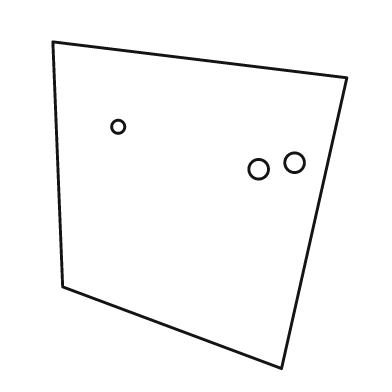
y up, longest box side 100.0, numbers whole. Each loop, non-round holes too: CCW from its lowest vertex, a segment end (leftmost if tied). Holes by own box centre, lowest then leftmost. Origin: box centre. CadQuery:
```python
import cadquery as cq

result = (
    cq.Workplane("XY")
    .moveTo(25.0, -50.0)
    .lineTo(45.0, 39.0)
    .lineTo(-45.0, 50.0)
    .lineTo(-42.0, -25.0)
    .close()
    .moveTo(18.0, 11.0)
    .circle(3.0)
    .moveTo(29.0, 13.0)
    .circle(3.0)
    .moveTo(-25.0, 24.0)
    .circle(2.0)
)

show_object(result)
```